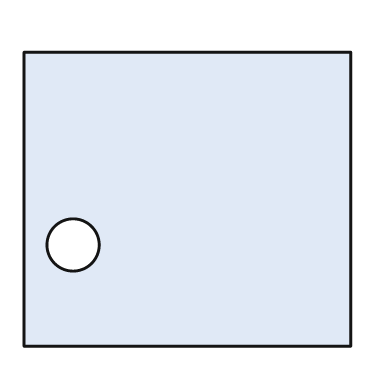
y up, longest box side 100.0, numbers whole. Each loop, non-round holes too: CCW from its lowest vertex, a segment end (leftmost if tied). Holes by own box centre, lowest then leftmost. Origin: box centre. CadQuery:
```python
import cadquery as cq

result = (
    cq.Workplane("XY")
    .moveTo(-50.0, -45.0)
    .lineTo(50.0, -45.0)
    .lineTo(50.0, 45.0)
    .lineTo(-50.0, 45.0)
    .close()
    .moveTo(-35.0, -14.0)
    .circle(8.0)
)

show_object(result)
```